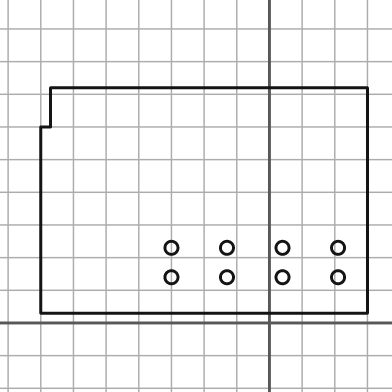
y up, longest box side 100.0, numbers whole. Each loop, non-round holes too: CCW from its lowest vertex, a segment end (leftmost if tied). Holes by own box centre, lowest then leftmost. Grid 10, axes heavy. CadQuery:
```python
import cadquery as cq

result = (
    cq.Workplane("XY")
    .moveTo(-70.0, 3.0)
    .lineTo(30.0, 3.0)
    .lineTo(30.0, 72.0)
    .lineTo(-67.0, 72.0)
    .lineTo(-67.0, 60.0)
    .lineTo(-70.0, 60.0)
    .close()
    .moveTo(-30.0, 14.0)
    .circle(2.0)
    .moveTo(-13.0, 14.0)
    .circle(2.0)
    .moveTo(4.0, 14.0)
    .circle(2.0)
    .moveTo(21.0, 14.0)
    .circle(2.0)
    .moveTo(-30.0, 23.0)
    .circle(2.0)
    .moveTo(-13.0, 23.0)
    .circle(2.0)
    .moveTo(4.0, 23.0)
    .circle(2.0)
    .moveTo(21.0, 23.0)
    .circle(2.0)
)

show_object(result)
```